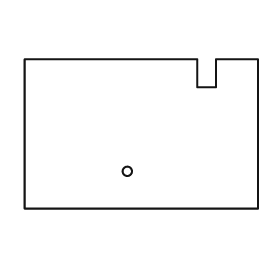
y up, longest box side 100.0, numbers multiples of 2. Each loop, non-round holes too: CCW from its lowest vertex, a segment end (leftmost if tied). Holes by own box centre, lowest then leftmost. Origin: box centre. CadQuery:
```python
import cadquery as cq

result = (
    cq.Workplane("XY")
    .moveTo(-50.0, -32.0)
    .lineTo(50.0, -32.0)
    .lineTo(50.0, 32.0)
    .lineTo(32.0, 32.0)
    .lineTo(32.0, 20.0)
    .lineTo(24.0, 20.0)
    .lineTo(24.0, 32.0)
    .lineTo(-50.0, 32.0)
    .close()
    .moveTo(-6.0, -16.0)
    .circle(2.0)
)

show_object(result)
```